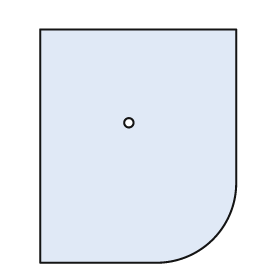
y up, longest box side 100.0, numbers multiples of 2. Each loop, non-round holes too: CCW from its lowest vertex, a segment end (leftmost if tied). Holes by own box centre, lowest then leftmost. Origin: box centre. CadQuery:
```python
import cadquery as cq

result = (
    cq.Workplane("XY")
    .moveTo(-42.0, -50.0)
    .lineTo(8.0, -50.0)
    .threePointArc((32.0, -40.0), (42.0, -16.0))
    .lineTo(42.0, 50.0)
    .lineTo(-42.0, 50.0)
    .close()
    .moveTo(-4.0, 10.0)
    .circle(2.0)
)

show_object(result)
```